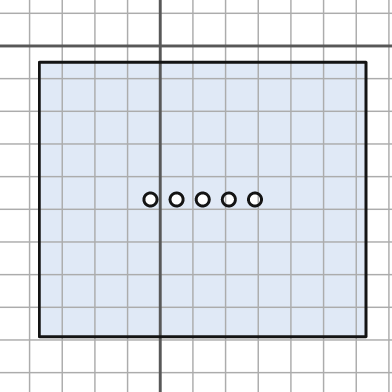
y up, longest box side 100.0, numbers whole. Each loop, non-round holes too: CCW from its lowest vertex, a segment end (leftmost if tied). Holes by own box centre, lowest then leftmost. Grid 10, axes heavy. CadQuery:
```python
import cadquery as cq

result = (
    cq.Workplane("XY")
    .moveTo(-37.0, -89.0)
    .lineTo(63.0, -89.0)
    .lineTo(63.0, -5.0)
    .lineTo(-37.0, -5.0)
    .close()
    .moveTo(-3.0, -47.0)
    .circle(2.0)
    .moveTo(5.0, -47.0)
    .circle(2.0)
    .moveTo(13.0, -47.0)
    .circle(2.0)
    .moveTo(21.0, -47.0)
    .circle(2.0)
    .moveTo(29.0, -47.0)
    .circle(2.0)
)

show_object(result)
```